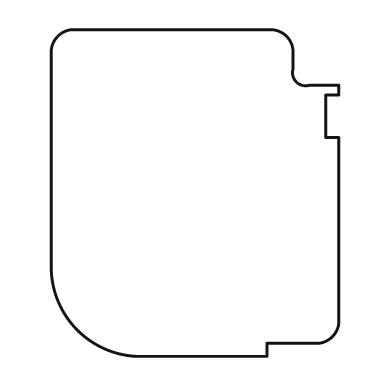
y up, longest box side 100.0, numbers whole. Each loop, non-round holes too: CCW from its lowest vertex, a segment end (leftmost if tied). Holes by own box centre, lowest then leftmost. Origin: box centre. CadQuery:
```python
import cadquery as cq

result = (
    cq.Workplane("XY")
    .moveTo(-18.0, -50.0)
    .lineTo(22.0, -50.0)
    .lineTo(22.0, -46.0)
    .lineTo(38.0, -46.0)
    .threePointArc((42.0, -44.0), (44.0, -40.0))
    .lineTo(44.0, 17.0)
    .lineTo(40.0, 17.0)
    .lineTo(40.0, 30.0)
    .lineTo(44.0, 30.0)
    .lineTo(44.0, 33.0)
    .lineTo(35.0, 33.0)
    .threePointArc((31.0, 34.0), (30.0, 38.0))
    .lineTo(30.0, 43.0)
    .threePointArc((28.0, 48.0), (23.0, 50.0))
    .lineTo(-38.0, 50.0)
    .threePointArc((-42.0, 48.0), (-44.0, 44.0))
    .lineTo(-44.0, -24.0)
    .threePointArc((-36.0, -42.0), (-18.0, -50.0))
    .close()
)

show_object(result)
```